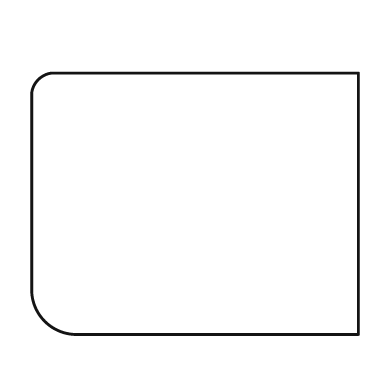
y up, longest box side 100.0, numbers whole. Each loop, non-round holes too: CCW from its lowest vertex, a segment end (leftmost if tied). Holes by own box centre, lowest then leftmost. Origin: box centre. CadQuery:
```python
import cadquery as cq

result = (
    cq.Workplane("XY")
    .moveTo(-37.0, -40.0)
    .lineTo(50.0, -40.0)
    .lineTo(50.0, 40.0)
    .lineTo(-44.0, 40.0)
    .threePointArc((-48.0, 38.0), (-50.0, 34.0))
    .lineTo(-50.0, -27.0)
    .threePointArc((-46.0, -36.0), (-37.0, -40.0))
    .close()
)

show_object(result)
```